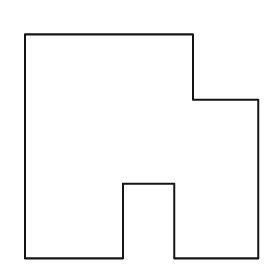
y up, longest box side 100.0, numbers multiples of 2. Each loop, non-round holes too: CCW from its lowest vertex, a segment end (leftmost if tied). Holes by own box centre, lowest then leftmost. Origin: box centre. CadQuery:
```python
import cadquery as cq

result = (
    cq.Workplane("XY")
    .moveTo(-50.0, -48.0)
    .lineTo(-8.0, -48.0)
    .lineTo(-8.0, -16.0)
    .lineTo(14.0, -16.0)
    .lineTo(14.0, -48.0)
    .lineTo(50.0, -48.0)
    .lineTo(50.0, 20.0)
    .lineTo(22.0, 20.0)
    .lineTo(22.0, 48.0)
    .lineTo(-50.0, 48.0)
    .close()
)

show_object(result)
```